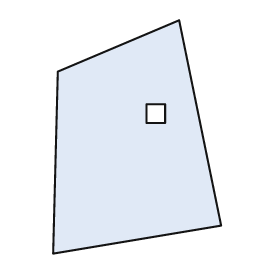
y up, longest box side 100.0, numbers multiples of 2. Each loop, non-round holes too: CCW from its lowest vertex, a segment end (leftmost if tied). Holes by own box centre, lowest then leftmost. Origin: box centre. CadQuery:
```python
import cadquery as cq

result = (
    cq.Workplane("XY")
    .moveTo(-36.0, -50.0)
    .lineTo(36.0, -38.0)
    .lineTo(18.0, 50.0)
    .lineTo(-34.0, 28.0)
    .close()
    .moveTo(4.0, 6.0)
    .lineTo(12.0, 6.0)
    .lineTo(12.0, 14.0)
    .lineTo(4.0, 14.0)
    .close()
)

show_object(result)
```